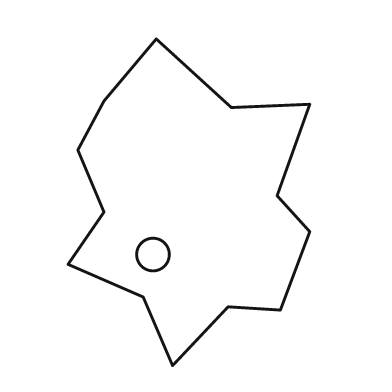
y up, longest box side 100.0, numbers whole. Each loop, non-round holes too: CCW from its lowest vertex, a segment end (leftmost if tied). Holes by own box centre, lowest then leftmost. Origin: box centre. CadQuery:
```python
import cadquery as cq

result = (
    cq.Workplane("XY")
    .moveTo(-5.0, -50.0)
    .lineTo(12.0, -32.0)
    .lineTo(28.0, -33.0)
    .lineTo(37.0, -9.0)
    .lineTo(27.0, 2.0)
    .lineTo(37.0, 30.0)
    .lineTo(13.0, 29.0)
    .lineTo(-10.0, 50.0)
    .lineTo(-26.0, 31.0)
    .lineTo(-34.0, 16.0)
    .lineTo(-26.0, -3.0)
    .lineTo(-37.0, -19.0)
    .lineTo(-14.0, -29.0)
    .close()
    .moveTo(-11.0, -16.0)
    .circle(5.0)
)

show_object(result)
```